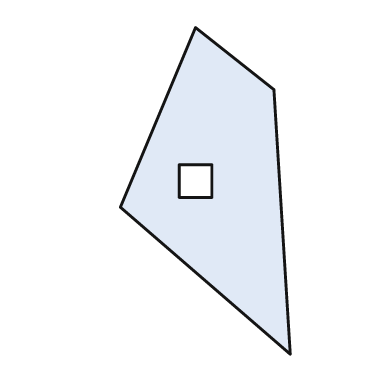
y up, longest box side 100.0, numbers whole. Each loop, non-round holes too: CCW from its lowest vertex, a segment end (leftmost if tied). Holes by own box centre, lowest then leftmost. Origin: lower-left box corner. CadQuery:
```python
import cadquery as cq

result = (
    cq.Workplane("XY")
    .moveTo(52.0, 0.0)
    .lineTo(47.0, 81.0)
    .lineTo(23.0, 100.0)
    .lineTo(0.0, 45.0)
    .close()
    .moveTo(18.0, 48.0)
    .lineTo(28.0, 48.0)
    .lineTo(28.0, 58.0)
    .lineTo(18.0, 58.0)
    .close()
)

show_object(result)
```